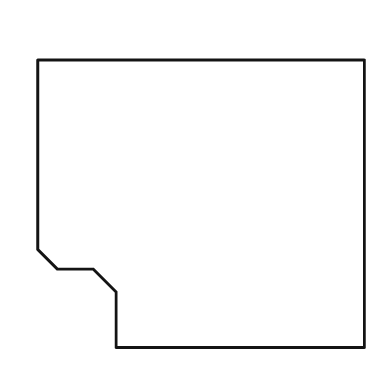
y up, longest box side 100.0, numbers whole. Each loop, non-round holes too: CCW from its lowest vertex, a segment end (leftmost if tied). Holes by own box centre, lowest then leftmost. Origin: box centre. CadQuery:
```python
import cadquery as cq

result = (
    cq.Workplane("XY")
    .moveTo(-26.0, -44.0)
    .lineTo(50.0, -44.0)
    .lineTo(50.0, 44.0)
    .lineTo(-50.0, 44.0)
    .lineTo(-50.0, -14.0)
    .lineTo(-44.0, -20.0)
    .lineTo(-33.0, -20.0)
    .lineTo(-26.0, -27.0)
    .close()
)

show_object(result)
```